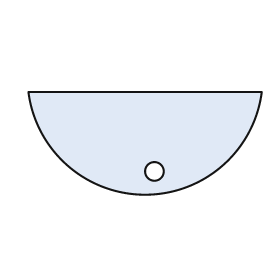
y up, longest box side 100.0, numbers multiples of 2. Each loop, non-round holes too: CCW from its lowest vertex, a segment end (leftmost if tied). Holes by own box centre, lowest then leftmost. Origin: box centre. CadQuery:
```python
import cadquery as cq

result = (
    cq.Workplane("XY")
    .moveTo(-50.0, 22.0)
    .threePointArc((0.0, -22.0), (50.0, 22.0))
    .close()
    .moveTo(4.0, -12.0)
    .circle(4.0)
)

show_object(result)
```